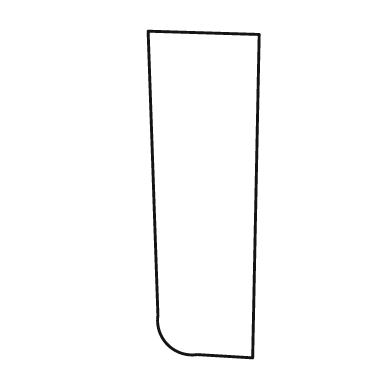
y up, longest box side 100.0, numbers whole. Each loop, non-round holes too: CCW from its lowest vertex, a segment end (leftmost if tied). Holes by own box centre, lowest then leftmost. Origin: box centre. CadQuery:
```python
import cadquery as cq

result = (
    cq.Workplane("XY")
    .moveTo(15.0, -50.0)
    .lineTo(17.0, 49.0)
    .lineTo(-17.0, 50.0)
    .lineTo(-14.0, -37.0)
    .threePointArc((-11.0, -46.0), (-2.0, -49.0))
    .close()
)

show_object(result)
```